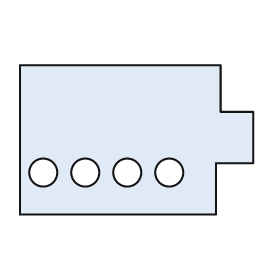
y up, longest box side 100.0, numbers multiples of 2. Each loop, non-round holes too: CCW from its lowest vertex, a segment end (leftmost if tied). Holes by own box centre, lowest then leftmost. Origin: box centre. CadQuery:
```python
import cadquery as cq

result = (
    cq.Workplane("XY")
    .moveTo(-50.0, -32.0)
    .lineTo(34.0, -32.0)
    .lineTo(34.0, -10.0)
    .lineTo(50.0, -10.0)
    .lineTo(50.0, 12.0)
    .lineTo(36.0, 12.0)
    .lineTo(36.0, 32.0)
    .lineTo(-50.0, 32.0)
    .close()
    .moveTo(-40.0, -14.0)
    .circle(6.0)
    .moveTo(-22.0, -14.0)
    .circle(6.0)
    .moveTo(-4.0, -14.0)
    .circle(6.0)
    .moveTo(14.0, -14.0)
    .circle(6.0)
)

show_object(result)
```